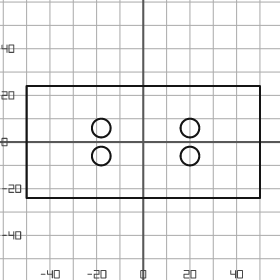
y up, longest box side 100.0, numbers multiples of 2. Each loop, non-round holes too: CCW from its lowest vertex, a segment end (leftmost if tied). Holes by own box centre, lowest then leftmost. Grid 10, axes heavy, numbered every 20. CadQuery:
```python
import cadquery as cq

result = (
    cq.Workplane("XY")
    .moveTo(-50.0, -24.0)
    .lineTo(50.0, -24.0)
    .lineTo(50.0, 24.0)
    .lineTo(-50.0, 24.0)
    .close()
    .moveTo(-18.0, -6.0)
    .circle(4.0)
    .moveTo(20.0, -6.0)
    .circle(4.0)
    .moveTo(-18.0, 6.0)
    .circle(4.0)
    .moveTo(20.0, 6.0)
    .circle(4.0)
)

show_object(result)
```